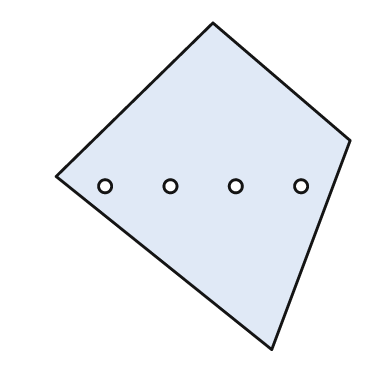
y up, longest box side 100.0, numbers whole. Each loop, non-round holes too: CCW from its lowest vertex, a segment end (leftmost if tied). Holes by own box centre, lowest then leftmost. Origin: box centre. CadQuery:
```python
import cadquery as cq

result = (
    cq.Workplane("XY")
    .moveTo(21.0, -50.0)
    .lineTo(45.0, 14.0)
    .lineTo(3.0, 50.0)
    .lineTo(-45.0, 3.0)
    .close()
    .moveTo(-30.0, 0.0)
    .circle(2.0)
    .moveTo(-10.0, 0.0)
    .circle(2.0)
    .moveTo(10.0, 0.0)
    .circle(2.0)
    .moveTo(30.0, 0.0)
    .circle(2.0)
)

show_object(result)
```